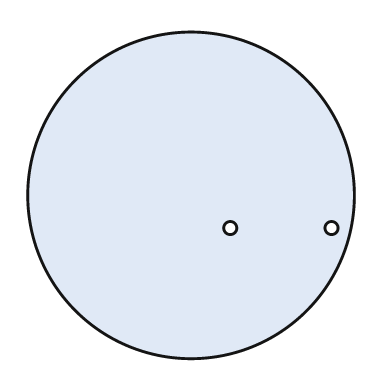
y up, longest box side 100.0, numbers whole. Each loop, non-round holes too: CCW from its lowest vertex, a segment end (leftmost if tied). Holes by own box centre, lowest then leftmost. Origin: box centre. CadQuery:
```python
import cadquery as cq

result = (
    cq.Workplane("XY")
    .moveTo(0.0, 0.0)
    .circle(50.0)
    .moveTo(12.0, -10.0)
    .circle(2.0)
    .moveTo(43.0, -10.0)
    .circle(2.0)
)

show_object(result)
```